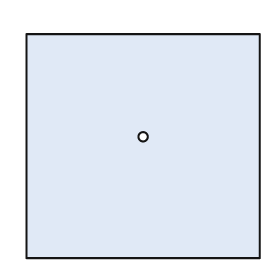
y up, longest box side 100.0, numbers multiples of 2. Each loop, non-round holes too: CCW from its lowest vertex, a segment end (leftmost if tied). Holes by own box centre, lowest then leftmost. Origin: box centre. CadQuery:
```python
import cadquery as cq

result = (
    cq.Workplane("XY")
    .moveTo(-50.0, -48.0)
    .lineTo(50.0, -48.0)
    .lineTo(50.0, 48.0)
    .lineTo(-50.0, 48.0)
    .close()
    .moveTo(0.0, 4.0)
    .circle(2.0)
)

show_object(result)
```